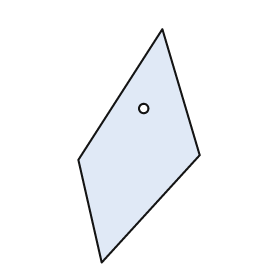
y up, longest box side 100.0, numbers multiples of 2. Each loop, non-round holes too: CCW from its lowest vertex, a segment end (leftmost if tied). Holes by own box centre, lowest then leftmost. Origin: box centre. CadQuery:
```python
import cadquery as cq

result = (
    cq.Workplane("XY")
    .moveTo(-16.0, -50.0)
    .lineTo(26.0, -4.0)
    .lineTo(10.0, 50.0)
    .lineTo(-26.0, -6.0)
    .close()
    .moveTo(2.0, 16.0)
    .circle(2.0)
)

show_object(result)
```